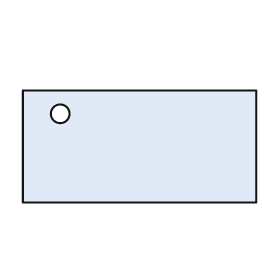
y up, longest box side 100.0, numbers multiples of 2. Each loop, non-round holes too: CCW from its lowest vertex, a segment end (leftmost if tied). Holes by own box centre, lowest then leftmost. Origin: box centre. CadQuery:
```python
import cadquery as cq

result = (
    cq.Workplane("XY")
    .moveTo(-50.0, -24.0)
    .lineTo(50.0, -24.0)
    .lineTo(50.0, 24.0)
    .lineTo(-50.0, 24.0)
    .close()
    .moveTo(-34.0, 14.0)
    .circle(4.0)
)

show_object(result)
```